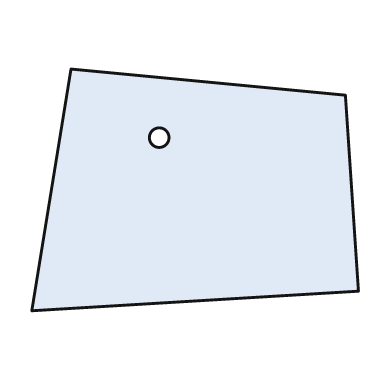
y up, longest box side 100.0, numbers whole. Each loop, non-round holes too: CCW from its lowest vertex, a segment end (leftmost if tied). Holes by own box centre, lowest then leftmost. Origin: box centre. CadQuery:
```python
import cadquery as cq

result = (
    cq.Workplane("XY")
    .moveTo(-50.0, -37.0)
    .lineTo(50.0, -31.0)
    .lineTo(46.0, 29.0)
    .lineTo(-38.0, 37.0)
    .close()
    .moveTo(-11.0, 16.0)
    .circle(3.0)
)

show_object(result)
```